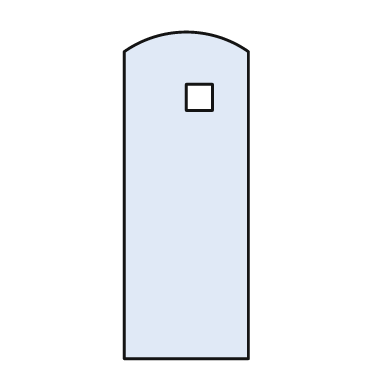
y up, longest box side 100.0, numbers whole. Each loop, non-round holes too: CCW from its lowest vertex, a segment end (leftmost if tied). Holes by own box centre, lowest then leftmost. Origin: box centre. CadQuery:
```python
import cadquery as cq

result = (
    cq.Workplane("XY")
    .moveTo(-19.0, -50.0)
    .lineTo(19.0, -50.0)
    .lineTo(19.0, 44.0)
    .threePointArc((0.0, 50.0), (-19.0, 44.0))
    .close()
    .moveTo(0.0, 26.0)
    .lineTo(8.0, 26.0)
    .lineTo(8.0, 34.0)
    .lineTo(0.0, 34.0)
    .close()
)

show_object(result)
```